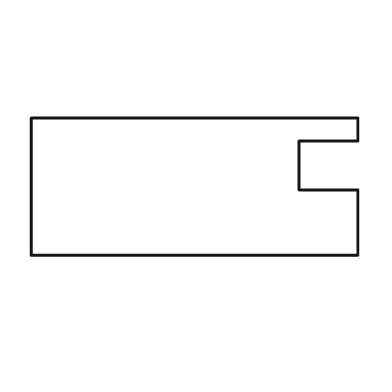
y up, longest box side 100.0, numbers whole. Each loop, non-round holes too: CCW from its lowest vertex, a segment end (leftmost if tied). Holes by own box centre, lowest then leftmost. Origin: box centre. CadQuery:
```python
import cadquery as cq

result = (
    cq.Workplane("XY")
    .moveTo(-50.0, -21.0)
    .lineTo(50.0, -21.0)
    .lineTo(50.0, -1.0)
    .lineTo(32.0, -1.0)
    .lineTo(32.0, 14.0)
    .lineTo(50.0, 14.0)
    .lineTo(50.0, 21.0)
    .lineTo(-50.0, 21.0)
    .close()
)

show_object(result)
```